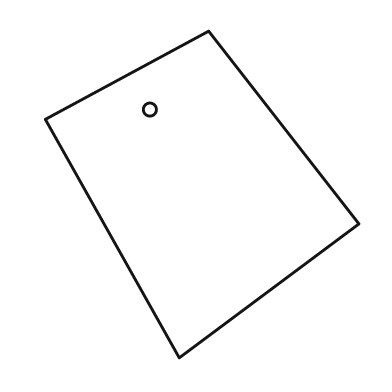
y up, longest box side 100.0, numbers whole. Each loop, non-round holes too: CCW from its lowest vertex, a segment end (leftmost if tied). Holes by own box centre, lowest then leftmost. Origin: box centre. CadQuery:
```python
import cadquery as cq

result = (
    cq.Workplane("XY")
    .moveTo(-7.0, -50.0)
    .lineTo(48.0, -9.0)
    .lineTo(2.0, 50.0)
    .lineTo(-48.0, 23.0)
    .close()
    .moveTo(-16.0, 26.0)
    .circle(2.0)
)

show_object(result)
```